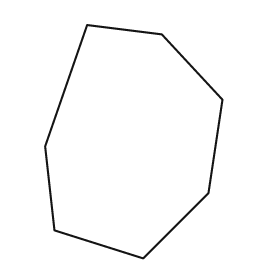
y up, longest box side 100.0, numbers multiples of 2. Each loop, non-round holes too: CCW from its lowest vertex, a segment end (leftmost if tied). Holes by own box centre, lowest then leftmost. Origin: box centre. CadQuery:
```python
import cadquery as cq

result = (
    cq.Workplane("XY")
    .moveTo(4.0, -50.0)
    .lineTo(32.0, -22.0)
    .lineTo(38.0, 18.0)
    .lineTo(12.0, 46.0)
    .lineTo(-20.0, 50.0)
    .lineTo(-38.0, -2.0)
    .lineTo(-34.0, -38.0)
    .close()
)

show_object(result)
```